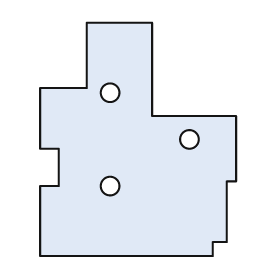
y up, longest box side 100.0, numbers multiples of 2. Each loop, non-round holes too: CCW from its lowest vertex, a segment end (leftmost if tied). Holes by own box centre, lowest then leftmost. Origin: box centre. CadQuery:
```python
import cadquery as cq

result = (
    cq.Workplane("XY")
    .moveTo(-42.0, -50.0)
    .lineTo(32.0, -50.0)
    .lineTo(32.0, -44.0)
    .lineTo(38.0, -44.0)
    .lineTo(38.0, -18.0)
    .lineTo(42.0, -18.0)
    .lineTo(42.0, 10.0)
    .lineTo(6.0, 10.0)
    .lineTo(6.0, 50.0)
    .lineTo(-22.0, 50.0)
    .lineTo(-22.0, 22.0)
    .lineTo(-42.0, 22.0)
    .lineTo(-42.0, -4.0)
    .lineTo(-34.0, -4.0)
    .lineTo(-34.0, -20.0)
    .lineTo(-42.0, -20.0)
    .close()
    .moveTo(-12.0, -20.0)
    .circle(4.0)
    .moveTo(22.0, 0.0)
    .circle(4.0)
    .moveTo(-12.0, 20.0)
    .circle(4.0)
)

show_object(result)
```